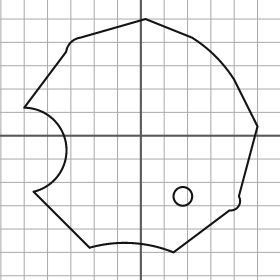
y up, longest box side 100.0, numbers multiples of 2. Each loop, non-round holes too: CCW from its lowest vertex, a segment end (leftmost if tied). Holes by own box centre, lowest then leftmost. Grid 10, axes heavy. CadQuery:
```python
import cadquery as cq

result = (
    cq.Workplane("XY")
    .moveTo(14.0, -50.0)
    .lineTo(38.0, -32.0)
    .threePointArc((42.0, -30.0), (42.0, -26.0))
    .lineTo(50.0, 4.0)
    .lineTo(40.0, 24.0)
    .threePointArc((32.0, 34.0), (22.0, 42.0))
    .lineTo(2.0, 50.0)
    .lineTo(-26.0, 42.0)
    .threePointArc((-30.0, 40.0), (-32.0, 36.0))
    .lineTo(-50.0, 12.0)
    .threePointArc((-32.0, -4.0), (-46.0, -24.0))
    .lineTo(-22.0, -48.0)
    .threePointArc((-4.0, -46.0), (14.0, -50.0))
    .close()
    .moveTo(18.0, -26.0)
    .circle(4.0)
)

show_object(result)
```